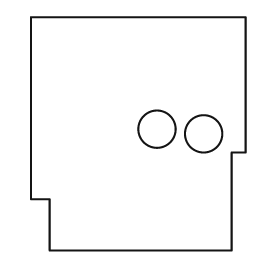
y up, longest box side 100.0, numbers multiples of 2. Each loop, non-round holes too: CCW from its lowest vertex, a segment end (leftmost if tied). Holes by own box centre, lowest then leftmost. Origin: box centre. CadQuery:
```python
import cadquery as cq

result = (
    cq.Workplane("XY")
    .moveTo(-38.0, -50.0)
    .lineTo(40.0, -50.0)
    .lineTo(40.0, -8.0)
    .lineTo(46.0, -8.0)
    .lineTo(46.0, 50.0)
    .lineTo(-46.0, 50.0)
    .lineTo(-46.0, -28.0)
    .lineTo(-38.0, -28.0)
    .close()
    .moveTo(28.0, 0.0)
    .circle(8.0)
    .moveTo(8.0, 2.0)
    .circle(8.0)
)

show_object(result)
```